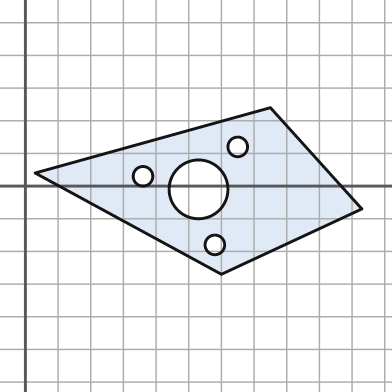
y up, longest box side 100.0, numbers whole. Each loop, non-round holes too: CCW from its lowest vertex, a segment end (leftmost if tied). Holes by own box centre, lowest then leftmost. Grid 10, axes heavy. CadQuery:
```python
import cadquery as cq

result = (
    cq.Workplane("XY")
    .moveTo(60.0, -27.0)
    .lineTo(103.0, -7.0)
    .lineTo(75.0, 24.0)
    .lineTo(3.0, 4.0)
    .close()
    .moveTo(58.0, -18.0)
    .circle(3.0)
    .moveTo(53.0, -1.0)
    .circle(9.0)
    .moveTo(36.0, 3.0)
    .circle(3.0)
    .moveTo(65.0, 12.0)
    .circle(3.0)
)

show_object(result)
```